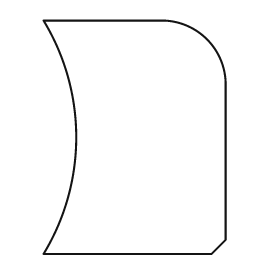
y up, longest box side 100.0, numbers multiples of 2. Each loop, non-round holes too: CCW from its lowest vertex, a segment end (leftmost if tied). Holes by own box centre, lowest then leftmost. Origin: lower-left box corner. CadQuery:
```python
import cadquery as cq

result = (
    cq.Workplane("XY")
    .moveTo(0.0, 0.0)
    .lineTo(72.0, 0.0)
    .lineTo(78.0, 6.0)
    .lineTo(78.0, 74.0)
    .threePointArc((70.0, 92.0), (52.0, 100.0))
    .lineTo(0.0, 100.0)
    .threePointArc((14.0, 50.0), (0.0, 0.0))
    .close()
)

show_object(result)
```